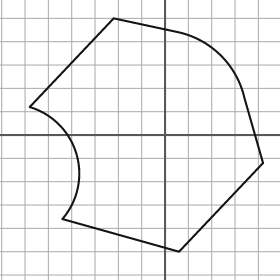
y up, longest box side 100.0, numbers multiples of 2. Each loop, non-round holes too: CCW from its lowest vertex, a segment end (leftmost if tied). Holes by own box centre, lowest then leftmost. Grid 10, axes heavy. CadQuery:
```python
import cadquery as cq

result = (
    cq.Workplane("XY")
    .moveTo(6.0, -50.0)
    .lineTo(42.0, -12.0)
    .lineTo(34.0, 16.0)
    .threePointArc((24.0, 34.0), (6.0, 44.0))
    .lineTo(-22.0, 50.0)
    .lineTo(-58.0, 12.0)
    .threePointArc((-38.0, -8.0), (-44.0, -36.0))
    .close()
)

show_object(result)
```